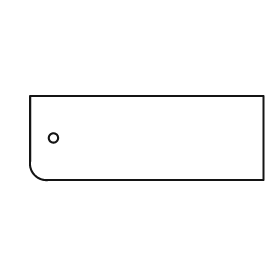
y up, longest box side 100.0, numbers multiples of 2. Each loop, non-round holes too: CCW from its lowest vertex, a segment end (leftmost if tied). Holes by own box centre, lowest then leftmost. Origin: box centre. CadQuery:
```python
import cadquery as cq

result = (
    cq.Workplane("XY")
    .moveTo(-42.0, -18.0)
    .lineTo(50.0, -18.0)
    .lineTo(50.0, 18.0)
    .lineTo(-50.0, 18.0)
    .lineTo(-50.0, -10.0)
    .threePointArc((-48.0, -16.0), (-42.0, -18.0))
    .close()
    .moveTo(-40.0, 0.0)
    .circle(2.0)
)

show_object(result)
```